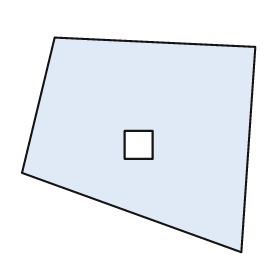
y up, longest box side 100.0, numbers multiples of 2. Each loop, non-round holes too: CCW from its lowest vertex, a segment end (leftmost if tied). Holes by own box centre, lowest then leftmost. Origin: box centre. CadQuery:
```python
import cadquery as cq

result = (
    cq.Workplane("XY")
    .moveTo(44.0, -46.0)
    .lineTo(50.0, 42.0)
    .lineTo(-36.0, 46.0)
    .lineTo(-50.0, -12.0)
    .close()
    .moveTo(-6.0, -6.0)
    .lineTo(6.0, -6.0)
    .lineTo(6.0, 6.0)
    .lineTo(-6.0, 6.0)
    .close()
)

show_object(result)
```